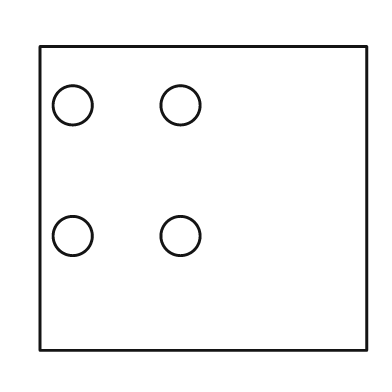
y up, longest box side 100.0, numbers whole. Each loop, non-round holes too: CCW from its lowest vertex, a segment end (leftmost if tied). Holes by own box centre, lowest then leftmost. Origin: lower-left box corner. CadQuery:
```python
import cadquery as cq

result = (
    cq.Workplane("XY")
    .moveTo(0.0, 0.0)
    .lineTo(100.0, 0.0)
    .lineTo(100.0, 93.0)
    .lineTo(0.0, 93.0)
    .close()
    .moveTo(10.0, 35.0)
    .circle(6.0)
    .moveTo(43.0, 35.0)
    .circle(6.0)
    .moveTo(10.0, 75.0)
    .circle(6.0)
    .moveTo(43.0, 75.0)
    .circle(6.0)
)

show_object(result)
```